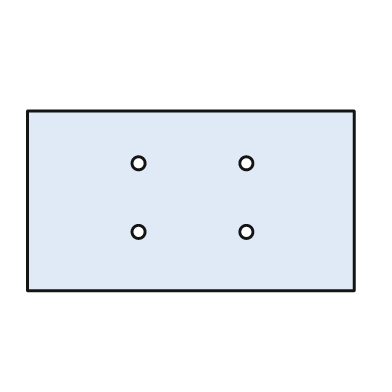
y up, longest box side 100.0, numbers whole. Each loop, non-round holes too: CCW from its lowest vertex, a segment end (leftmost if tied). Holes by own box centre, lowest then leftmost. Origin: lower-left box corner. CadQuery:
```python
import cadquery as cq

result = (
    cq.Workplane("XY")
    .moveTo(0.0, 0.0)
    .lineTo(100.0, 0.0)
    .lineTo(100.0, 55.0)
    .lineTo(0.0, 55.0)
    .close()
    .moveTo(34.0, 18.0)
    .circle(2.0)
    .moveTo(67.0, 18.0)
    .circle(2.0)
    .moveTo(34.0, 39.0)
    .circle(2.0)
    .moveTo(67.0, 39.0)
    .circle(2.0)
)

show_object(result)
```